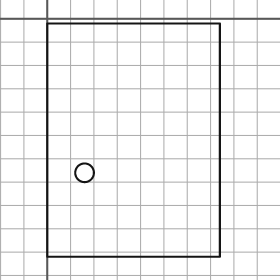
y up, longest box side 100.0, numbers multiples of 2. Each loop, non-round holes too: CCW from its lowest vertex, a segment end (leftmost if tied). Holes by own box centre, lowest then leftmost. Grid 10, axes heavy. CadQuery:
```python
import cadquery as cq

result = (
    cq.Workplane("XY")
    .moveTo(0.0, -102.0)
    .lineTo(74.0, -102.0)
    .lineTo(74.0, -2.0)
    .lineTo(0.0, -2.0)
    .close()
    .moveTo(16.0, -66.0)
    .circle(4.0)
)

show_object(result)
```